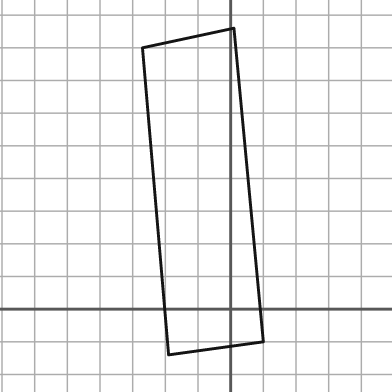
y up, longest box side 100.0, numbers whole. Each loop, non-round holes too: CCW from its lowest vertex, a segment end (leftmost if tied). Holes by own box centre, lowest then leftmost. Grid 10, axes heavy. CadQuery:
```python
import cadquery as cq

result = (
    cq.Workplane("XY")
    .moveTo(-19.0, -14.0)
    .lineTo(10.0, -10.0)
    .lineTo(1.0, 86.0)
    .lineTo(-27.0, 80.0)
    .close()
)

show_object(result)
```